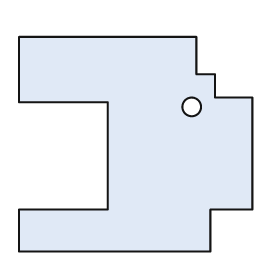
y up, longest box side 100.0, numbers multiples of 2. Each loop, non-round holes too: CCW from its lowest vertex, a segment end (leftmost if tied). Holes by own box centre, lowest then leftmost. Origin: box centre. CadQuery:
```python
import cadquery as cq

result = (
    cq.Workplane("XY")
    .moveTo(-50.0, -46.0)
    .lineTo(32.0, -46.0)
    .lineTo(32.0, -28.0)
    .lineTo(50.0, -28.0)
    .lineTo(50.0, 20.0)
    .lineTo(34.0, 20.0)
    .lineTo(34.0, 30.0)
    .lineTo(26.0, 30.0)
    .lineTo(26.0, 46.0)
    .lineTo(-50.0, 46.0)
    .lineTo(-50.0, 18.0)
    .lineTo(-12.0, 18.0)
    .lineTo(-12.0, -28.0)
    .lineTo(-50.0, -28.0)
    .close()
    .moveTo(24.0, 16.0)
    .circle(4.0)
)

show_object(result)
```